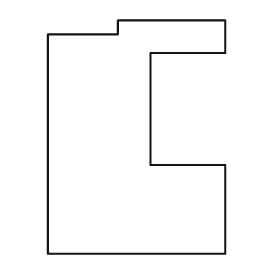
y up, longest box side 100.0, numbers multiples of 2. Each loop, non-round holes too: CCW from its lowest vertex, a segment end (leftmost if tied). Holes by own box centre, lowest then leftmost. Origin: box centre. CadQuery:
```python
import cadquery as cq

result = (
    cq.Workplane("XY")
    .moveTo(-38.0, -50.0)
    .lineTo(38.0, -50.0)
    .lineTo(38.0, -12.0)
    .lineTo(6.0, -12.0)
    .lineTo(6.0, 36.0)
    .lineTo(38.0, 36.0)
    .lineTo(38.0, 50.0)
    .lineTo(-8.0, 50.0)
    .lineTo(-8.0, 44.0)
    .lineTo(-38.0, 44.0)
    .close()
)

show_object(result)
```